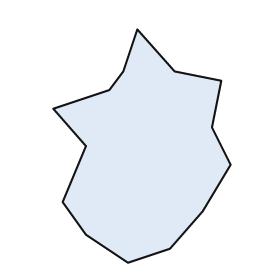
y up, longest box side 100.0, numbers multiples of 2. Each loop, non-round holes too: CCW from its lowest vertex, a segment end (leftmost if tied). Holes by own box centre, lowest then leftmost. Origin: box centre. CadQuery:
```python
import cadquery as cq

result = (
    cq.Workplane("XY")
    .moveTo(-6.0, -50.0)
    .lineTo(12.0, -44.0)
    .lineTo(26.0, -28.0)
    .lineTo(38.0, -8.0)
    .lineTo(30.0, 8.0)
    .lineTo(34.0, 28.0)
    .lineTo(14.0, 32.0)
    .lineTo(-2.0, 50.0)
    .lineTo(-8.0, 32.0)
    .lineTo(-14.0, 24.0)
    .lineTo(-38.0, 16.0)
    .lineTo(-24.0, 0.0)
    .lineTo(-34.0, -24.0)
    .lineTo(-24.0, -38.0)
    .close()
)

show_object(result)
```